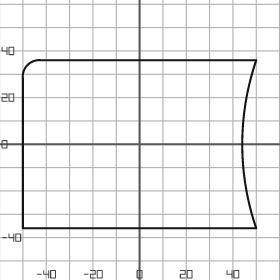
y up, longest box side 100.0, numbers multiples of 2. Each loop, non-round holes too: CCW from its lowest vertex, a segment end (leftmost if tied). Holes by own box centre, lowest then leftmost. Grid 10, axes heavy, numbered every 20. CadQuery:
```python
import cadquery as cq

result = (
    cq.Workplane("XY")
    .moveTo(-50.0, -36.0)
    .lineTo(50.0, -36.0)
    .threePointArc((44.0, 0.0), (50.0, 36.0))
    .lineTo(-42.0, 36.0)
    .threePointArc((-48.0, 34.0), (-50.0, 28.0))
    .close()
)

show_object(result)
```